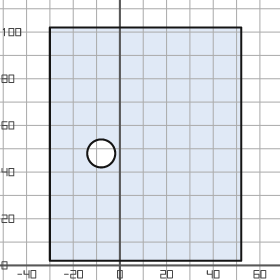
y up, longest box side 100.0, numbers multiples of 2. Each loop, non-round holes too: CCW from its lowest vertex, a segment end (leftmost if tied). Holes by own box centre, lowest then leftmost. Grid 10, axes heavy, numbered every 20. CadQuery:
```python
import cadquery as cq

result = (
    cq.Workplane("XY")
    .moveTo(-30.0, 2.0)
    .lineTo(52.0, 2.0)
    .lineTo(52.0, 102.0)
    .lineTo(-30.0, 102.0)
    .close()
    .moveTo(-8.0, 48.0)
    .circle(6.0)
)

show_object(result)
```